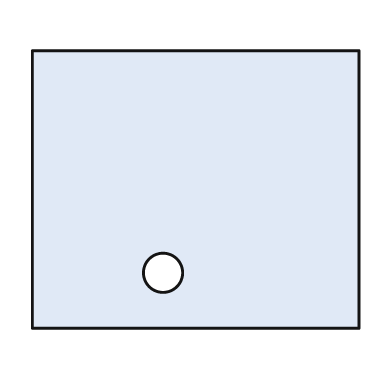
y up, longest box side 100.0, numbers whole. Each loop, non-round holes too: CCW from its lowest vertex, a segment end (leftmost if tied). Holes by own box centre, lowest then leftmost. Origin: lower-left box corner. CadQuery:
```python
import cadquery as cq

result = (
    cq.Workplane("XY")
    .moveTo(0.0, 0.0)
    .lineTo(100.0, 0.0)
    .lineTo(100.0, 85.0)
    .lineTo(0.0, 85.0)
    .close()
    .moveTo(40.0, 17.0)
    .circle(6.0)
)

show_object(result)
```